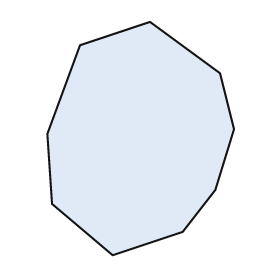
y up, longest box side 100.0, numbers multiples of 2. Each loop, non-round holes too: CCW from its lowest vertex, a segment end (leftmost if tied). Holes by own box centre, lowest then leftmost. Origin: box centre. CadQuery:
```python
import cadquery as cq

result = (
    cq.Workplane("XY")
    .moveTo(-12.0, -50.0)
    .lineTo(18.0, -40.0)
    .lineTo(32.0, -22.0)
    .lineTo(40.0, 4.0)
    .lineTo(34.0, 28.0)
    .lineTo(4.0, 50.0)
    .lineTo(-26.0, 40.0)
    .lineTo(-40.0, 2.0)
    .lineTo(-38.0, -28.0)
    .close()
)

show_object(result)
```